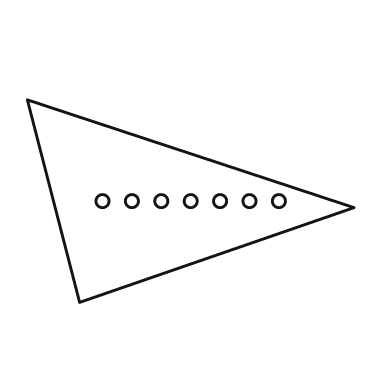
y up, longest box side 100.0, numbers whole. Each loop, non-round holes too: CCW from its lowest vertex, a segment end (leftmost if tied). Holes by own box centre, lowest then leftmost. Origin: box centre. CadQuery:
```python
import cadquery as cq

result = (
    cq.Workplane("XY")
    .moveTo(-34.0, -31.0)
    .lineTo(50.0, -2.0)
    .lineTo(-50.0, 31.0)
    .close()
    .moveTo(-27.0, 0.0)
    .circle(2.0)
    .moveTo(-18.0, 0.0)
    .circle(2.0)
    .moveTo(-9.0, 0.0)
    .circle(2.0)
    .moveTo(0.0, 0.0)
    .circle(2.0)
    .moveTo(9.0, 0.0)
    .circle(2.0)
    .moveTo(18.0, 0.0)
    .circle(2.0)
    .moveTo(27.0, 0.0)
    .circle(2.0)
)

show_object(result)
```